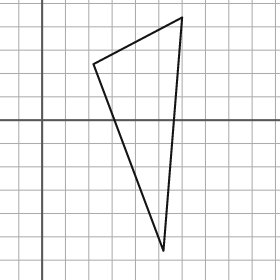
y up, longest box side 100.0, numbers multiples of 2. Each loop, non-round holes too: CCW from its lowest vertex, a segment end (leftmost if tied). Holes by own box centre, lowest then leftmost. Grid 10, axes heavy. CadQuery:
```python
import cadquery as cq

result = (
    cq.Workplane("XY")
    .moveTo(52.0, -56.0)
    .lineTo(60.0, 44.0)
    .lineTo(22.0, 24.0)
    .close()
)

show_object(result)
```